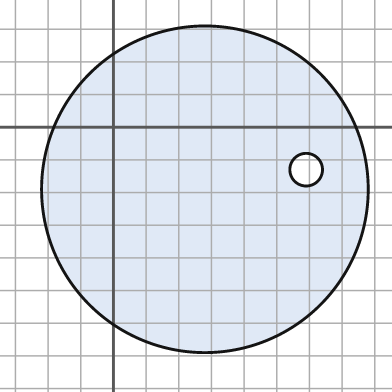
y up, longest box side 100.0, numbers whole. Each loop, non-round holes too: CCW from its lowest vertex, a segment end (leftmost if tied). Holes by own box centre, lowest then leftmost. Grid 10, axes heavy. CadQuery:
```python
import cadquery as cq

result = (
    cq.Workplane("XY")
    .moveTo(28.0, -19.0)
    .circle(50.0)
    .moveTo(59.0, -13.0)
    .circle(5.0)
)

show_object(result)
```